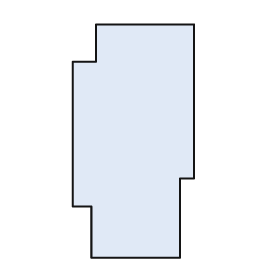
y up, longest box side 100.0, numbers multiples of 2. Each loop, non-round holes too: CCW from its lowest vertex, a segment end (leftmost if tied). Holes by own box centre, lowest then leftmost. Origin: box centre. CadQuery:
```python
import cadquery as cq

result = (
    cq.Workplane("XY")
    .moveTo(-18.0, -50.0)
    .lineTo(20.0, -50.0)
    .lineTo(20.0, -16.0)
    .lineTo(26.0, -16.0)
    .lineTo(26.0, 50.0)
    .lineTo(-16.0, 50.0)
    .lineTo(-16.0, 34.0)
    .lineTo(-26.0, 34.0)
    .lineTo(-26.0, -28.0)
    .lineTo(-18.0, -28.0)
    .close()
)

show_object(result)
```